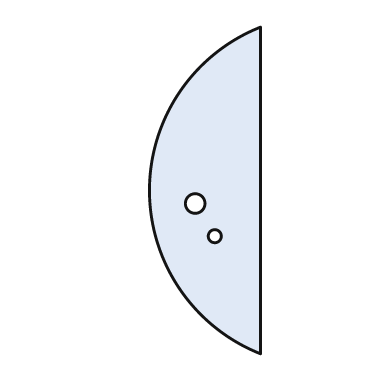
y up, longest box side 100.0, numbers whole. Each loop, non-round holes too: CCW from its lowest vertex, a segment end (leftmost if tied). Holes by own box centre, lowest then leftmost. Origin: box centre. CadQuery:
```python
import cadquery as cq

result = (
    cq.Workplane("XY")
    .moveTo(17.0, -50.0)
    .lineTo(17.0, 50.0)
    .threePointArc((-17.0, 0.0), (17.0, -50.0))
    .close()
    .moveTo(3.0, -14.0)
    .circle(2.0)
    .moveTo(-3.0, -4.0)
    .circle(3.0)
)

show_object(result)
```